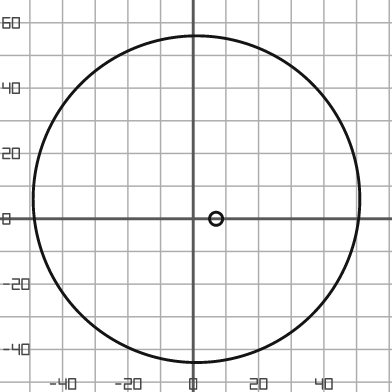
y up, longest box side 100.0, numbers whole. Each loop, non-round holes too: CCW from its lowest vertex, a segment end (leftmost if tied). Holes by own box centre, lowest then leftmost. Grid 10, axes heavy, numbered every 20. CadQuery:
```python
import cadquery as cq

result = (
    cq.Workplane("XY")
    .moveTo(1.0, 6.0)
    .circle(50.0)
    .moveTo(7.0, 0.0)
    .circle(2.0)
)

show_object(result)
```